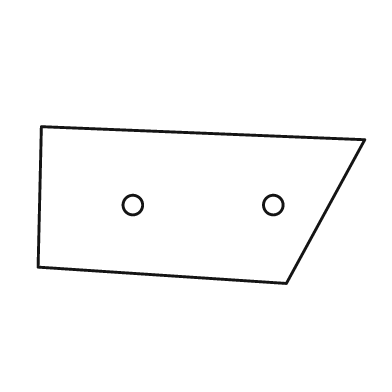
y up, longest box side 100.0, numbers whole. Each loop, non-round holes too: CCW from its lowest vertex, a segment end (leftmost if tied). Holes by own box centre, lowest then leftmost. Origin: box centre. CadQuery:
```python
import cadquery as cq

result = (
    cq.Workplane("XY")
    .moveTo(26.0, -24.0)
    .lineTo(50.0, 20.0)
    .lineTo(-49.0, 24.0)
    .lineTo(-50.0, -19.0)
    .close()
    .moveTo(-21.0, 0.0)
    .circle(3.0)
    .moveTo(22.0, 0.0)
    .circle(3.0)
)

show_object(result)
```